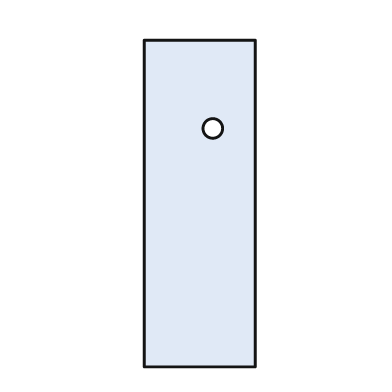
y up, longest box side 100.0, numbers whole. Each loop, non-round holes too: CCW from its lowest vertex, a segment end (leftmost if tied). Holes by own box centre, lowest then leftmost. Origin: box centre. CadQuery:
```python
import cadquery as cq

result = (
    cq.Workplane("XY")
    .moveTo(-17.0, -50.0)
    .lineTo(17.0, -50.0)
    .lineTo(17.0, 50.0)
    .lineTo(-17.0, 50.0)
    .close()
    .moveTo(4.0, 23.0)
    .circle(3.0)
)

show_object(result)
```